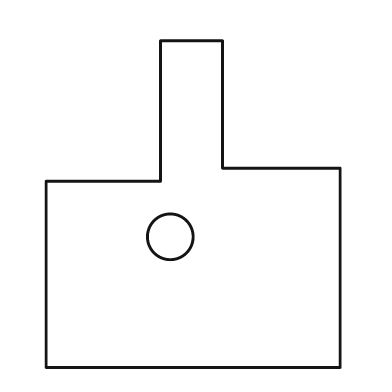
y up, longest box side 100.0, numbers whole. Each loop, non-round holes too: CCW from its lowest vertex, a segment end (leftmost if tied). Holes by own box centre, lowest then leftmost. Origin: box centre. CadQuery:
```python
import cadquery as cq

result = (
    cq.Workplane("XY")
    .moveTo(-45.0, -50.0)
    .lineTo(45.0, -50.0)
    .lineTo(45.0, 11.0)
    .lineTo(9.0, 11.0)
    .lineTo(9.0, 50.0)
    .lineTo(-10.0, 50.0)
    .lineTo(-10.0, 7.0)
    .lineTo(-45.0, 7.0)
    .close()
    .moveTo(-7.0, -10.0)
    .circle(7.0)
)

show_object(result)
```